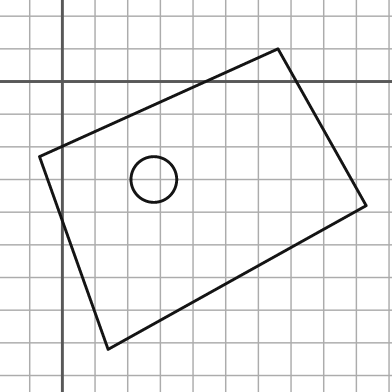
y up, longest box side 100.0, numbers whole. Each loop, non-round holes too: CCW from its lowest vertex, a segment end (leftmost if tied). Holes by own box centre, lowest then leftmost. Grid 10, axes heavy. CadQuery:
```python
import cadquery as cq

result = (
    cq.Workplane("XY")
    .moveTo(14.0, -82.0)
    .lineTo(93.0, -38.0)
    .lineTo(66.0, 10.0)
    .lineTo(-7.0, -23.0)
    .close()
    .moveTo(28.0, -30.0)
    .circle(7.0)
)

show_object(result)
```